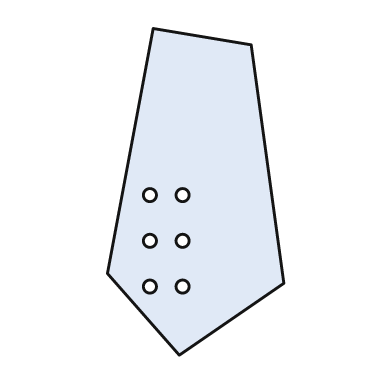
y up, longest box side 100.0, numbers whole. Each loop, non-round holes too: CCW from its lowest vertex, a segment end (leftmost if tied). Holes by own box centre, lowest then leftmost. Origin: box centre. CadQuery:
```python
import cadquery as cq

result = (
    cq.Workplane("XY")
    .moveTo(-5.0, -50.0)
    .lineTo(27.0, -28.0)
    .lineTo(17.0, 45.0)
    .lineTo(-13.0, 50.0)
    .lineTo(-27.0, -25.0)
    .close()
    .moveTo(-14.0, -29.0)
    .circle(2.0)
    .moveTo(-4.0, -29.0)
    .circle(2.0)
    .moveTo(-14.0, -15.0)
    .circle(2.0)
    .moveTo(-4.0, -15.0)
    .circle(2.0)
    .moveTo(-14.0, -1.0)
    .circle(2.0)
    .moveTo(-4.0, -1.0)
    .circle(2.0)
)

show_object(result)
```